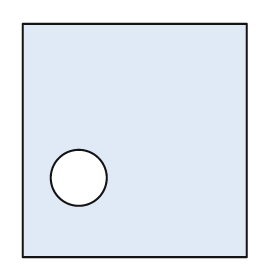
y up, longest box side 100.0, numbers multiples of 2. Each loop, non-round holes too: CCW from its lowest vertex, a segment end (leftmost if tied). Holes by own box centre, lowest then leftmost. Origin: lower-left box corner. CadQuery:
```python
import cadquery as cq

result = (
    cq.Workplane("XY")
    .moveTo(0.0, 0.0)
    .lineTo(96.0, 0.0)
    .lineTo(96.0, 100.0)
    .lineTo(0.0, 100.0)
    .close()
    .moveTo(24.0, 34.0)
    .circle(12.0)
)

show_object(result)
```